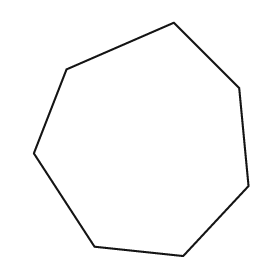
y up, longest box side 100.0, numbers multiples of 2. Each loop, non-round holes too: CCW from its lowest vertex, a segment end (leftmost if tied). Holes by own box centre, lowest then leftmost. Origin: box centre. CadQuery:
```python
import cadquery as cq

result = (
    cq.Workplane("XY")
    .moveTo(18.0, -50.0)
    .lineTo(46.0, -20.0)
    .lineTo(42.0, 22.0)
    .lineTo(14.0, 50.0)
    .lineTo(-32.0, 30.0)
    .lineTo(-46.0, -6.0)
    .lineTo(-20.0, -46.0)
    .close()
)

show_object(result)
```